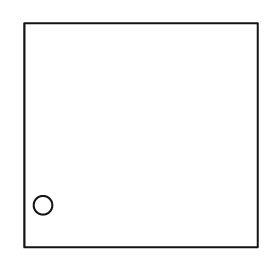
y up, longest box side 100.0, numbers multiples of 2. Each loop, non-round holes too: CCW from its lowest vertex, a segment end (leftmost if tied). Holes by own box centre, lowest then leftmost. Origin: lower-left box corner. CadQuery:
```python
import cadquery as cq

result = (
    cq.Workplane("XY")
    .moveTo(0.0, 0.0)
    .lineTo(100.0, 0.0)
    .lineTo(100.0, 96.0)
    .lineTo(0.0, 96.0)
    .close()
    .moveTo(8.0, 18.0)
    .circle(4.0)
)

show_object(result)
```